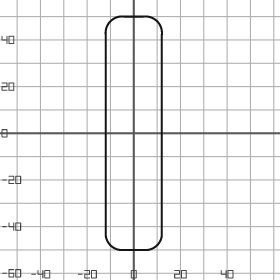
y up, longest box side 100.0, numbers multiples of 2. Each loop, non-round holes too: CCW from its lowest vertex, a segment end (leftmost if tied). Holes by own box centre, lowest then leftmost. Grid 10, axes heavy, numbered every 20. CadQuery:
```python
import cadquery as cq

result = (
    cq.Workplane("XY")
    .moveTo(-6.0, -50.0)
    .lineTo(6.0, -50.0)
    .threePointArc((10.0, -48.0), (12.0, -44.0))
    .lineTo(12.0, 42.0)
    .threePointArc((10.0, 48.0), (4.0, 50.0))
    .lineTo(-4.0, 50.0)
    .threePointArc((-10.0, 48.0), (-12.0, 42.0))
    .lineTo(-12.0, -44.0)
    .threePointArc((-10.0, -48.0), (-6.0, -50.0))
    .close()
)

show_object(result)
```